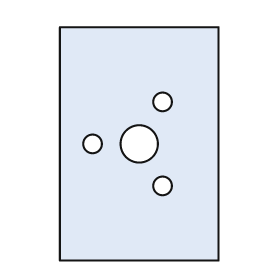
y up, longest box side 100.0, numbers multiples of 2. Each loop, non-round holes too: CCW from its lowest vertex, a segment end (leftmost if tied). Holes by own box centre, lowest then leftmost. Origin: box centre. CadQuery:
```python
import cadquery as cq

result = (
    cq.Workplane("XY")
    .moveTo(-34.0, -50.0)
    .lineTo(34.0, -50.0)
    .lineTo(34.0, 50.0)
    .lineTo(-34.0, 50.0)
    .close()
    .moveTo(10.0, -18.0)
    .circle(4.0)
    .moveTo(-20.0, 0.0)
    .circle(4.0)
    .moveTo(0.0, 0.0)
    .circle(8.0)
    .moveTo(10.0, 18.0)
    .circle(4.0)
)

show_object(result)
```